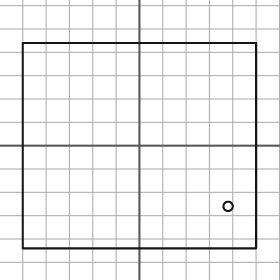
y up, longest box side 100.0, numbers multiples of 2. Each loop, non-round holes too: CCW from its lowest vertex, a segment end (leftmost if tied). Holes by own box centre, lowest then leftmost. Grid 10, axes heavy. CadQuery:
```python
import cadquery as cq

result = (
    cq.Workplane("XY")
    .moveTo(-50.0, -44.0)
    .lineTo(50.0, -44.0)
    .lineTo(50.0, 44.0)
    .lineTo(-50.0, 44.0)
    .close()
    .moveTo(38.0, -26.0)
    .circle(2.0)
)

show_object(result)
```